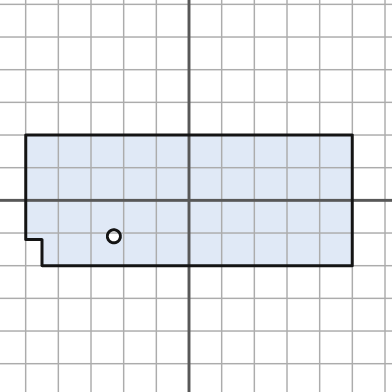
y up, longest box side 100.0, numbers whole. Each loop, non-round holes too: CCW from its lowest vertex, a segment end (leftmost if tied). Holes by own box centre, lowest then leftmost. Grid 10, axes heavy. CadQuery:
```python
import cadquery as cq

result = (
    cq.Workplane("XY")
    .moveTo(-45.0, -20.0)
    .lineTo(50.0, -20.0)
    .lineTo(50.0, 20.0)
    .lineTo(-50.0, 20.0)
    .lineTo(-50.0, -12.0)
    .lineTo(-45.0, -12.0)
    .close()
    .moveTo(-23.0, -11.0)
    .circle(2.0)
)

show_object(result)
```